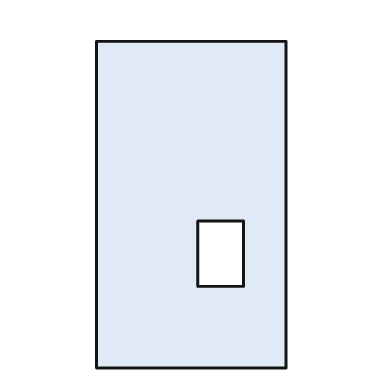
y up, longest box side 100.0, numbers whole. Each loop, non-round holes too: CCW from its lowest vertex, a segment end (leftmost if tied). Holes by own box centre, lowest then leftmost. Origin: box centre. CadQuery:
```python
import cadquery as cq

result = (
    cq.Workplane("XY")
    .moveTo(-29.0, -50.0)
    .lineTo(29.0, -50.0)
    .lineTo(29.0, 50.0)
    .lineTo(-29.0, 50.0)
    .close()
    .moveTo(2.0, -25.0)
    .lineTo(16.0, -25.0)
    .lineTo(16.0, -5.0)
    .lineTo(2.0, -5.0)
    .close()
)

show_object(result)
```